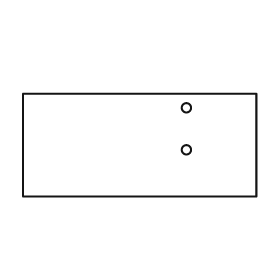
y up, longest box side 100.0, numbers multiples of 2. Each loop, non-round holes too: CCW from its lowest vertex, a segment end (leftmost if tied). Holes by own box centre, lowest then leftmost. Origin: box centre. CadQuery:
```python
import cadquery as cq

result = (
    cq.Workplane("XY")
    .moveTo(-50.0, -22.0)
    .lineTo(50.0, -22.0)
    .lineTo(50.0, 22.0)
    .lineTo(-50.0, 22.0)
    .close()
    .moveTo(20.0, -2.0)
    .circle(2.0)
    .moveTo(20.0, 16.0)
    .circle(2.0)
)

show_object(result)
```